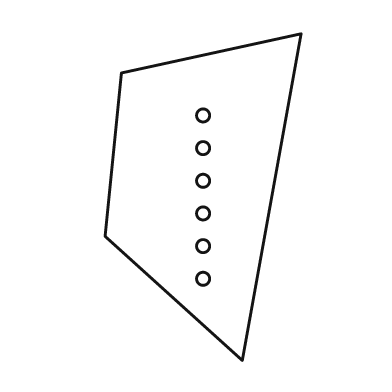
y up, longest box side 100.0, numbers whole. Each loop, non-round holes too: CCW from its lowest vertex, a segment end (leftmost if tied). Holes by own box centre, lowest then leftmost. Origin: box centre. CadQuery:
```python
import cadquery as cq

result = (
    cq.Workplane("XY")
    .moveTo(12.0, -50.0)
    .lineTo(30.0, 50.0)
    .lineTo(-25.0, 38.0)
    .lineTo(-30.0, -12.0)
    .close()
    .moveTo(0.0, -25.0)
    .circle(2.0)
    .moveTo(0.0, -15.0)
    .circle(2.0)
    .moveTo(0.0, -5.0)
    .circle(2.0)
    .moveTo(0.0, 5.0)
    .circle(2.0)
    .moveTo(0.0, 15.0)
    .circle(2.0)
    .moveTo(0.0, 25.0)
    .circle(2.0)
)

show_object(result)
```